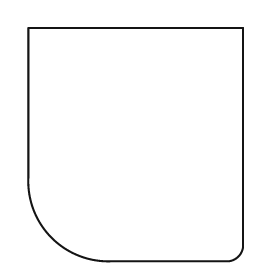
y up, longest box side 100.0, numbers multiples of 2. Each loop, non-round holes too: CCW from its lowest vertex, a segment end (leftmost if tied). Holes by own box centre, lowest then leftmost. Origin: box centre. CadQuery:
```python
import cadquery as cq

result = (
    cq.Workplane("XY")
    .moveTo(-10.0, -50.0)
    .lineTo(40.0, -50.0)
    .threePointArc((44.0, -48.0), (46.0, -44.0))
    .lineTo(46.0, 50.0)
    .lineTo(-46.0, 50.0)
    .lineTo(-46.0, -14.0)
    .threePointArc((-36.0, -40.0), (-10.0, -50.0))
    .close()
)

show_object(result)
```